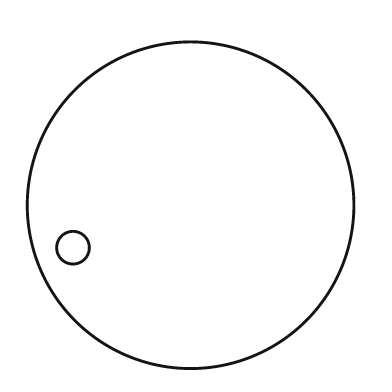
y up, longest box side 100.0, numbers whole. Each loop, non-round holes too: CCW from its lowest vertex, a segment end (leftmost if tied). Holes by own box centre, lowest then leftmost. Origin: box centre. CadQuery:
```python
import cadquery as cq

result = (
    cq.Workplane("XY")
    .moveTo(0.0, 0.0)
    .circle(50.0)
    .moveTo(-36.0, -13.0)
    .circle(5.0)
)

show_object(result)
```